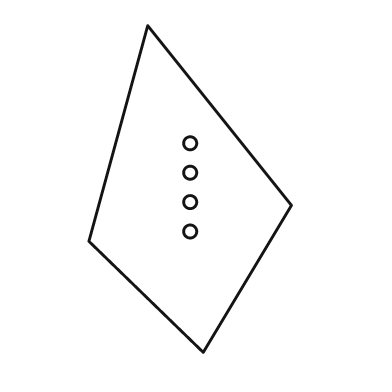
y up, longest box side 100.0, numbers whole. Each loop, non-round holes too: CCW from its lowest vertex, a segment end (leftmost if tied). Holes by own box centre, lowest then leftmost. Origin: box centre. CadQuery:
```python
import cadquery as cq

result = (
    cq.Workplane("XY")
    .moveTo(4.0, -50.0)
    .lineTo(31.0, -5.0)
    .lineTo(-13.0, 50.0)
    .lineTo(-31.0, -16.0)
    .close()
    .moveTo(0.0, -13.0)
    .circle(2.0)
    .moveTo(0.0, -4.0)
    .circle(2.0)
    .moveTo(0.0, 5.0)
    .circle(2.0)
    .moveTo(0.0, 14.0)
    .circle(2.0)
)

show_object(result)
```